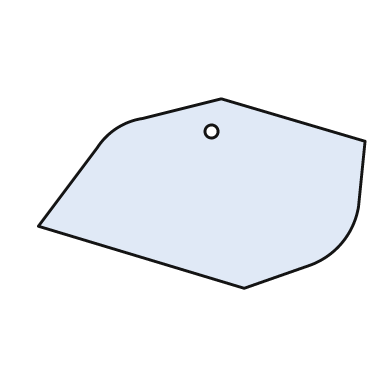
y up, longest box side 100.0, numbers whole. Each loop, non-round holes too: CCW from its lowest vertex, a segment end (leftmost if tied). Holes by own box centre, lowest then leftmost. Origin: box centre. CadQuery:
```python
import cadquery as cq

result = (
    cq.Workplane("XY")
    .moveTo(13.0, -29.0)
    .lineTo(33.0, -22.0)
    .threePointArc((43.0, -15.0), (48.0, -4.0))
    .lineTo(50.0, 16.0)
    .lineTo(6.0, 29.0)
    .lineTo(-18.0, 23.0)
    .threePointArc((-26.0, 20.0), (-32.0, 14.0))
    .lineTo(-50.0, -10.0)
    .close()
    .moveTo(3.0, 19.0)
    .circle(2.0)
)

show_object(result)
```